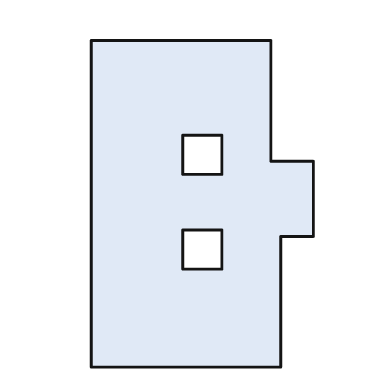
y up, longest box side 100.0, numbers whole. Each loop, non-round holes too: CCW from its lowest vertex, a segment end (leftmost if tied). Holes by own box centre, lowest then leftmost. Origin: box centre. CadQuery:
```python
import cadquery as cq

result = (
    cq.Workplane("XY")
    .moveTo(-34.0, -50.0)
    .lineTo(24.0, -50.0)
    .lineTo(24.0, -10.0)
    .lineTo(34.0, -10.0)
    .lineTo(34.0, 13.0)
    .lineTo(21.0, 13.0)
    .lineTo(21.0, 50.0)
    .lineTo(-34.0, 50.0)
    .close()
    .moveTo(-6.0, -20.0)
    .lineTo(6.0, -20.0)
    .lineTo(6.0, -8.0)
    .lineTo(-6.0, -8.0)
    .close()
    .moveTo(-6.0, 9.0)
    .lineTo(6.0, 9.0)
    .lineTo(6.0, 21.0)
    .lineTo(-6.0, 21.0)
    .close()
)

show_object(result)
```